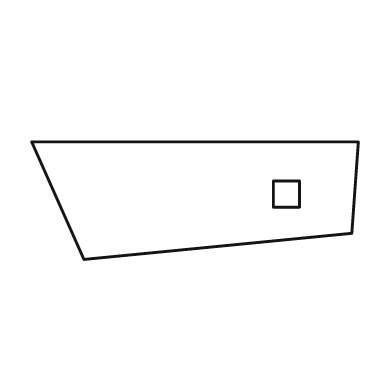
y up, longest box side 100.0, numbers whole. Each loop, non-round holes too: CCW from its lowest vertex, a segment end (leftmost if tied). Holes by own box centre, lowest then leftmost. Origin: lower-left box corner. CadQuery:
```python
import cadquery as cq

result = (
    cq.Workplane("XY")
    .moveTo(16.0, 0.0)
    .lineTo(98.0, 8.0)
    .lineTo(100.0, 36.0)
    .lineTo(0.0, 36.0)
    .close()
    .moveTo(74.0, 16.0)
    .lineTo(82.0, 16.0)
    .lineTo(82.0, 24.0)
    .lineTo(74.0, 24.0)
    .close()
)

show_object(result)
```